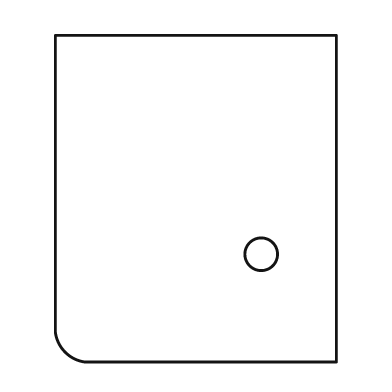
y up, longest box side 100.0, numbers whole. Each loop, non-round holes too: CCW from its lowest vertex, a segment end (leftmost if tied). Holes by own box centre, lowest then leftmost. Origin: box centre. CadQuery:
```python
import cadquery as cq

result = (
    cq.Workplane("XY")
    .moveTo(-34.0, -50.0)
    .lineTo(43.0, -50.0)
    .lineTo(43.0, 50.0)
    .lineTo(-43.0, 50.0)
    .lineTo(-43.0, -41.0)
    .threePointArc((-40.0, -47.0), (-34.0, -50.0))
    .close()
    .moveTo(20.0, -17.0)
    .circle(5.0)
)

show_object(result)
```